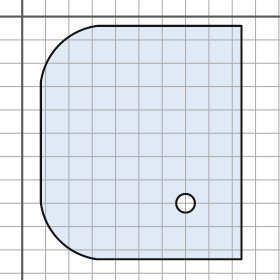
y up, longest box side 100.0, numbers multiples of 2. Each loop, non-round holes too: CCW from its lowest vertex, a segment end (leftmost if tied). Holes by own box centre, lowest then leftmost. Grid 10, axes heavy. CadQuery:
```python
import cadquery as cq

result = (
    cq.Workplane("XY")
    .moveTo(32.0, -104.0)
    .lineTo(94.0, -104.0)
    .lineTo(94.0, -4.0)
    .lineTo(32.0, -4.0)
    .threePointArc((16.0, -12.0), (8.0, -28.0))
    .lineTo(8.0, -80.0)
    .threePointArc((16.0, -96.0), (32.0, -104.0))
    .close()
    .moveTo(70.0, -80.0)
    .circle(4.0)
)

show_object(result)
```